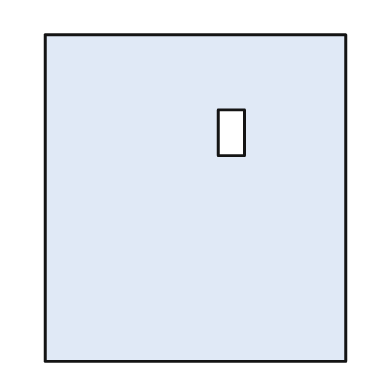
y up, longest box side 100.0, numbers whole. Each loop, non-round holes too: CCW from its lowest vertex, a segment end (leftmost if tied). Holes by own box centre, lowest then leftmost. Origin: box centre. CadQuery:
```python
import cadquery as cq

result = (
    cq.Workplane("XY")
    .moveTo(-46.0, -50.0)
    .lineTo(46.0, -50.0)
    .lineTo(46.0, 50.0)
    .lineTo(-46.0, 50.0)
    .close()
    .moveTo(7.0, 13.0)
    .lineTo(15.0, 13.0)
    .lineTo(15.0, 27.0)
    .lineTo(7.0, 27.0)
    .close()
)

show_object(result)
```